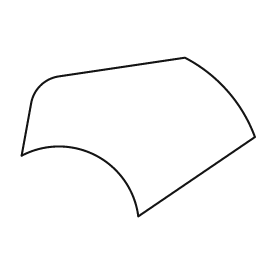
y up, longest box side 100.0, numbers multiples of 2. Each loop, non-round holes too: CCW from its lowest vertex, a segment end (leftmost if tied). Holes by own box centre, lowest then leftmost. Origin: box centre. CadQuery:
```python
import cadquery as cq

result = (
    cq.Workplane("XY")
    .moveTo(0.0, -34.0)
    .lineTo(50.0, 0.0)
    .threePointArc((38.0, 20.0), (20.0, 34.0))
    .lineTo(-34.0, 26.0)
    .threePointArc((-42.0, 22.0), (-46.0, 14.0))
    .lineTo(-50.0, -8.0)
    .threePointArc((-18.0, -8.0), (0.0, -34.0))
    .close()
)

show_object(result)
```